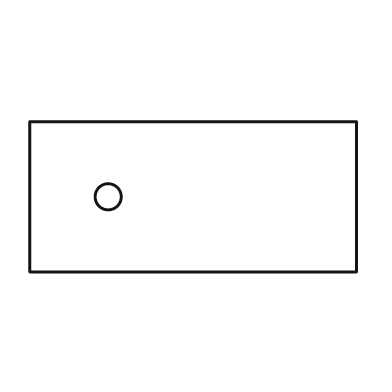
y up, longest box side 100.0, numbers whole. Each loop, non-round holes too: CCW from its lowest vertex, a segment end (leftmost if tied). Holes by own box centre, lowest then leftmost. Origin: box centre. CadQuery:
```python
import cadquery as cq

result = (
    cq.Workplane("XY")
    .moveTo(-50.0, -23.0)
    .lineTo(50.0, -23.0)
    .lineTo(50.0, 23.0)
    .lineTo(-50.0, 23.0)
    .close()
    .moveTo(-26.0, 0.0)
    .circle(4.0)
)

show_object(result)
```